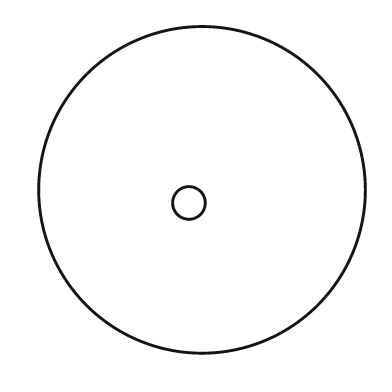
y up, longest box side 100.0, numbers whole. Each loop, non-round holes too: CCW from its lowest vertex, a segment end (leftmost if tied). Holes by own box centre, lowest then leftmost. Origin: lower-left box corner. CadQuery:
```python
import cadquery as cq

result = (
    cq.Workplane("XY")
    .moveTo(50.0, 50.0)
    .circle(50.0)
    .moveTo(46.0, 46.0)
    .circle(5.0)
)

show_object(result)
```